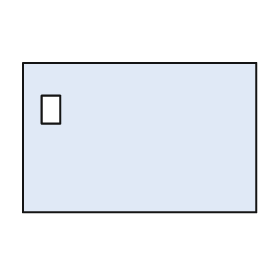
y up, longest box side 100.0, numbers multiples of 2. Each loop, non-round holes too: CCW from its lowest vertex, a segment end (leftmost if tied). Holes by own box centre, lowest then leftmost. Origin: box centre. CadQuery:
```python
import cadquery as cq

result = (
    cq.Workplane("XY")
    .moveTo(-50.0, -32.0)
    .lineTo(50.0, -32.0)
    .lineTo(50.0, 32.0)
    .lineTo(-50.0, 32.0)
    .close()
    .moveTo(-42.0, 6.0)
    .lineTo(-34.0, 6.0)
    .lineTo(-34.0, 18.0)
    .lineTo(-42.0, 18.0)
    .close()
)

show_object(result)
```